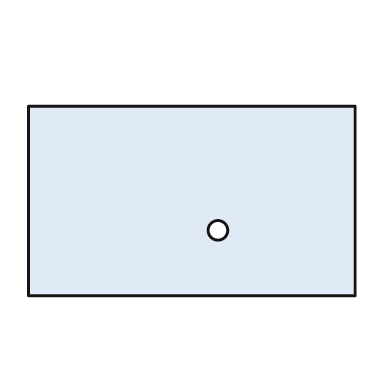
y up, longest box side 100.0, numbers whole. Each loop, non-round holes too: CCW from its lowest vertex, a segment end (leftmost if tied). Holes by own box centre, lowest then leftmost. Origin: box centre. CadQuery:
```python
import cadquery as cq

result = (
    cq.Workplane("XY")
    .moveTo(-50.0, -29.0)
    .lineTo(50.0, -29.0)
    .lineTo(50.0, 29.0)
    .lineTo(-50.0, 29.0)
    .close()
    .moveTo(8.0, -9.0)
    .circle(3.0)
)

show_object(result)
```